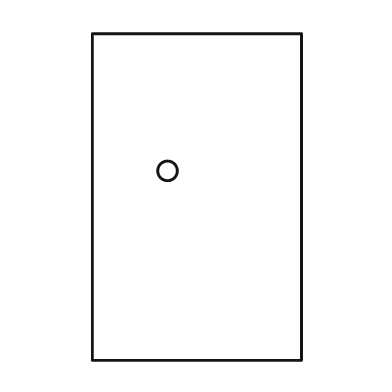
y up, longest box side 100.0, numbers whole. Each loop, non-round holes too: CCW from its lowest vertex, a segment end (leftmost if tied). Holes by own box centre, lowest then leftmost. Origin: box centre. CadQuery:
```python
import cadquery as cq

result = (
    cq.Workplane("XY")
    .moveTo(-32.0, -50.0)
    .lineTo(32.0, -50.0)
    .lineTo(32.0, 50.0)
    .lineTo(-32.0, 50.0)
    .close()
    .moveTo(-9.0, 8.0)
    .circle(3.0)
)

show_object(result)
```